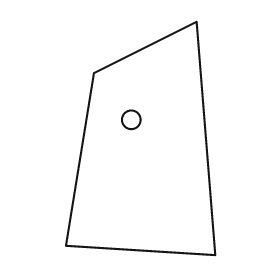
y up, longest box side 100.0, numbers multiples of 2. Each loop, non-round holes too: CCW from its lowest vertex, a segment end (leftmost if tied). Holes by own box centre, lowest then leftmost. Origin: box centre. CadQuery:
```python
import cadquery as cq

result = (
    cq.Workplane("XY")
    .moveTo(32.0, -50.0)
    .lineTo(24.0, 50.0)
    .lineTo(-20.0, 28.0)
    .lineTo(-32.0, -46.0)
    .close()
    .moveTo(-4.0, 8.0)
    .circle(4.0)
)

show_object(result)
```